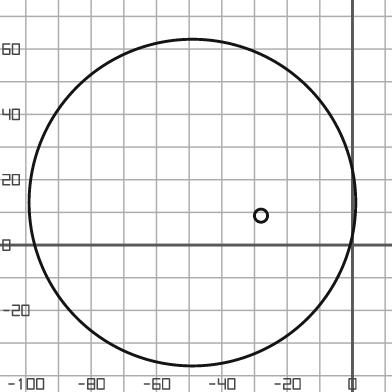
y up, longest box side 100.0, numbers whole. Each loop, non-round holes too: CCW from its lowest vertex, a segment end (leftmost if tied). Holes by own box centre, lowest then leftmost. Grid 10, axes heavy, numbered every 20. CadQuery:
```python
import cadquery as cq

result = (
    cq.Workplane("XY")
    .moveTo(-49.0, 13.0)
    .circle(50.0)
    .moveTo(-28.0, 9.0)
    .circle(2.0)
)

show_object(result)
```